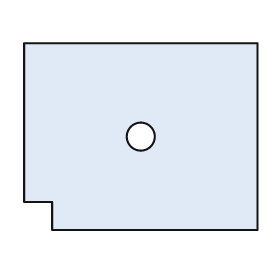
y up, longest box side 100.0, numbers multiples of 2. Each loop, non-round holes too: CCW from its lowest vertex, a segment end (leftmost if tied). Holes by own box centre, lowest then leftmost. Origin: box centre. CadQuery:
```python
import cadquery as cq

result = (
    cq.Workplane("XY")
    .moveTo(-38.0, -40.0)
    .lineTo(50.0, -40.0)
    .lineTo(50.0, 40.0)
    .lineTo(-50.0, 40.0)
    .lineTo(-50.0, -28.0)
    .lineTo(-38.0, -28.0)
    .close()
    .moveTo(0.0, 0.0)
    .circle(6.0)
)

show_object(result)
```